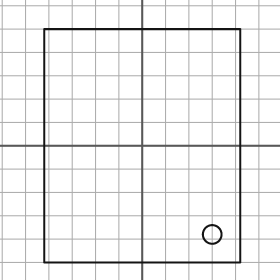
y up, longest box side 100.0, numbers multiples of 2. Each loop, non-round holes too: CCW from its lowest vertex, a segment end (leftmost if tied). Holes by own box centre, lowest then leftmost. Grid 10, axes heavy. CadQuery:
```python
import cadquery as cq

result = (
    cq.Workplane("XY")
    .moveTo(-42.0, -50.0)
    .lineTo(42.0, -50.0)
    .lineTo(42.0, 50.0)
    .lineTo(-42.0, 50.0)
    .close()
    .moveTo(30.0, -38.0)
    .circle(4.0)
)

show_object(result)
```